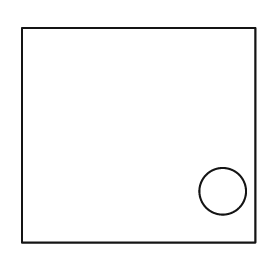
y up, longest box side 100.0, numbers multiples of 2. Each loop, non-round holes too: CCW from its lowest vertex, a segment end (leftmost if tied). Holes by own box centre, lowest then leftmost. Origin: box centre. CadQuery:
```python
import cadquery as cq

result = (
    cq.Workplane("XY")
    .moveTo(-50.0, -46.0)
    .lineTo(50.0, -46.0)
    .lineTo(50.0, 46.0)
    .lineTo(-50.0, 46.0)
    .close()
    .moveTo(36.0, -24.0)
    .circle(10.0)
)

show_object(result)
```